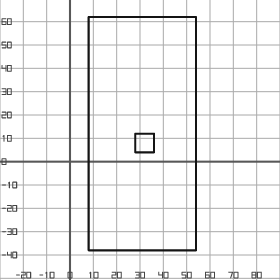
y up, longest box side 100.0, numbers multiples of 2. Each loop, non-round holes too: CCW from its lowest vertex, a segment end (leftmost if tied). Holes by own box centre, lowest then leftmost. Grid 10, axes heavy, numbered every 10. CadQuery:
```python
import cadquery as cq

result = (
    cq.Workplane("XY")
    .moveTo(8.0, -38.0)
    .lineTo(54.0, -38.0)
    .lineTo(54.0, 62.0)
    .lineTo(8.0, 62.0)
    .close()
    .moveTo(28.0, 4.0)
    .lineTo(36.0, 4.0)
    .lineTo(36.0, 12.0)
    .lineTo(28.0, 12.0)
    .close()
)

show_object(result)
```